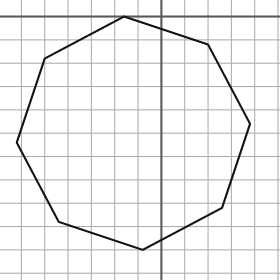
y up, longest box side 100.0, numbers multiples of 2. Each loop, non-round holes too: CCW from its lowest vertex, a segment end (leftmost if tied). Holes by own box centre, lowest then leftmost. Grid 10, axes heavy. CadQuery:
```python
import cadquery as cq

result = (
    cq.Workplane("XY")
    .moveTo(-8.0, -100.0)
    .lineTo(26.0, -82.0)
    .lineTo(38.0, -46.0)
    .lineTo(20.0, -12.0)
    .lineTo(-16.0, 0.0)
    .lineTo(-50.0, -18.0)
    .lineTo(-62.0, -54.0)
    .lineTo(-44.0, -88.0)
    .close()
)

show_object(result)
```